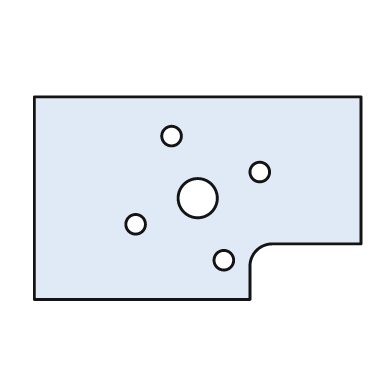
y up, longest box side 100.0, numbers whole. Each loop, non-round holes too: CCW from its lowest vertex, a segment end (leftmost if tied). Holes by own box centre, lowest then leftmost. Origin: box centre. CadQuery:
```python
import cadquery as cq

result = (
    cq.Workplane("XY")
    .moveTo(-50.0, -31.0)
    .lineTo(16.0, -31.0)
    .lineTo(16.0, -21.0)
    .threePointArc((18.0, -16.0), (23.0, -14.0))
    .lineTo(50.0, -14.0)
    .lineTo(50.0, 31.0)
    .lineTo(-50.0, 31.0)
    .close()
    .moveTo(8.0, -19.0)
    .circle(3.0)
    .moveTo(-19.0, -8.0)
    .circle(3.0)
    .moveTo(0.0, 0.0)
    .circle(6.0)
    .moveTo(19.0, 8.0)
    .circle(3.0)
    .moveTo(-8.0, 19.0)
    .circle(3.0)
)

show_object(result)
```